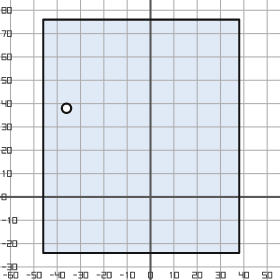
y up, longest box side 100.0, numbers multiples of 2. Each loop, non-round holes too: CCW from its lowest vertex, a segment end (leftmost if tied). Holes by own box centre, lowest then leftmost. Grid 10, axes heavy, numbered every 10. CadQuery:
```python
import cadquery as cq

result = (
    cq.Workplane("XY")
    .moveTo(-46.0, -24.0)
    .lineTo(38.0, -24.0)
    .lineTo(38.0, 76.0)
    .lineTo(-46.0, 76.0)
    .close()
    .moveTo(-36.0, 38.0)
    .circle(2.0)
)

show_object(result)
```